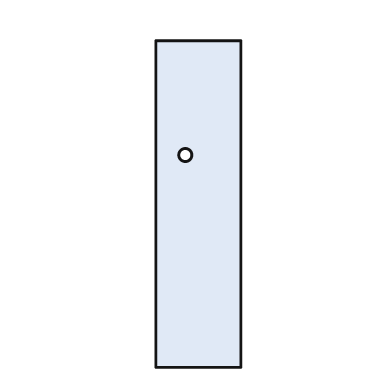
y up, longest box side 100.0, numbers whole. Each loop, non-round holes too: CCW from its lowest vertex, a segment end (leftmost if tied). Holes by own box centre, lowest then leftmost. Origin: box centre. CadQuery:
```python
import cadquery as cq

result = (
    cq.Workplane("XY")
    .moveTo(-13.0, -50.0)
    .lineTo(13.0, -50.0)
    .lineTo(13.0, 50.0)
    .lineTo(-13.0, 50.0)
    .close()
    .moveTo(-4.0, 15.0)
    .circle(2.0)
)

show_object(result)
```